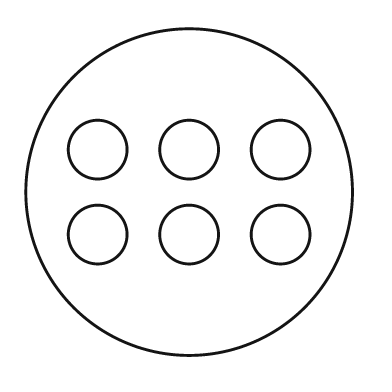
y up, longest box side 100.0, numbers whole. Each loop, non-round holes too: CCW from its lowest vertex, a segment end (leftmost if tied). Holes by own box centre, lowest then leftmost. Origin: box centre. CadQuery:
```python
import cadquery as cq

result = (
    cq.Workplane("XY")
    .moveTo(0.0, 0.0)
    .circle(50.0)
    .moveTo(-28.0, -13.0)
    .circle(9.0)
    .moveTo(0.0, -13.0)
    .circle(9.0)
    .moveTo(28.0, -13.0)
    .circle(9.0)
    .moveTo(-28.0, 13.0)
    .circle(9.0)
    .moveTo(0.0, 13.0)
    .circle(9.0)
    .moveTo(28.0, 13.0)
    .circle(9.0)
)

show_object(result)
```